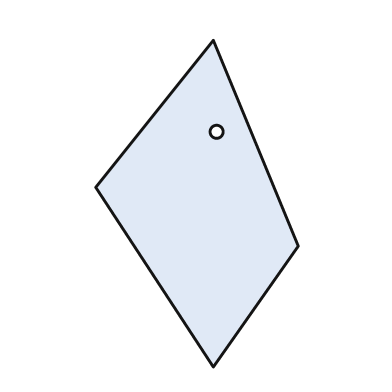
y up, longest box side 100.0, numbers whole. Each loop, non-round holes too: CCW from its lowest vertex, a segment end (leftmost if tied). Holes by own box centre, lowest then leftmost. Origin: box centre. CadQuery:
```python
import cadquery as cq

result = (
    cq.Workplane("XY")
    .moveTo(5.0, -50.0)
    .lineTo(31.0, -13.0)
    .lineTo(5.0, 50.0)
    .lineTo(-31.0, 5.0)
    .close()
    .moveTo(6.0, 22.0)
    .circle(2.0)
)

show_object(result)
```